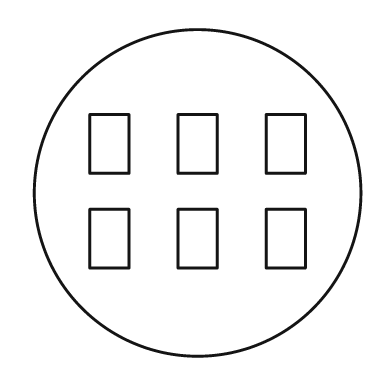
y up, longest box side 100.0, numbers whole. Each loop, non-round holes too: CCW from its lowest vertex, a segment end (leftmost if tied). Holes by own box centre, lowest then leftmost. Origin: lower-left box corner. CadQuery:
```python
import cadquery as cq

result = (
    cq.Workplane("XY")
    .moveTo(50.0, 50.0)
    .circle(50.0)
    .moveTo(17.0, 27.0)
    .lineTo(29.0, 27.0)
    .lineTo(29.0, 45.0)
    .lineTo(17.0, 45.0)
    .close()
    .moveTo(44.0, 27.0)
    .lineTo(56.0, 27.0)
    .lineTo(56.0, 45.0)
    .lineTo(44.0, 45.0)
    .close()
    .moveTo(71.0, 27.0)
    .lineTo(83.0, 27.0)
    .lineTo(83.0, 45.0)
    .lineTo(71.0, 45.0)
    .close()
    .moveTo(17.0, 56.0)
    .lineTo(29.0, 56.0)
    .lineTo(29.0, 74.0)
    .lineTo(17.0, 74.0)
    .close()
    .moveTo(44.0, 56.0)
    .lineTo(56.0, 56.0)
    .lineTo(56.0, 74.0)
    .lineTo(44.0, 74.0)
    .close()
    .moveTo(71.0, 56.0)
    .lineTo(83.0, 56.0)
    .lineTo(83.0, 74.0)
    .lineTo(71.0, 74.0)
    .close()
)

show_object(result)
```